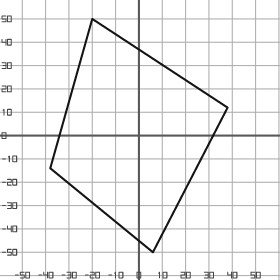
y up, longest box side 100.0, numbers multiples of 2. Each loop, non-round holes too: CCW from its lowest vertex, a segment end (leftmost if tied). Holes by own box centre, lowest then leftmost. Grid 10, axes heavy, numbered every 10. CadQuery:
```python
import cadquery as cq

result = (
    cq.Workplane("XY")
    .moveTo(6.0, -50.0)
    .lineTo(38.0, 12.0)
    .lineTo(-20.0, 50.0)
    .lineTo(-38.0, -14.0)
    .close()
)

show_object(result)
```